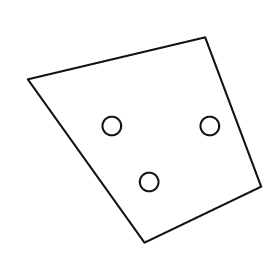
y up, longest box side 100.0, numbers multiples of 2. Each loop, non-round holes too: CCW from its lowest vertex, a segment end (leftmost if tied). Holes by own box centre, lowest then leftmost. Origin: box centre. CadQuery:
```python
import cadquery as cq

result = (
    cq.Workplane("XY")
    .moveTo(0.0, -44.0)
    .lineTo(50.0, -20.0)
    .lineTo(26.0, 44.0)
    .lineTo(-50.0, 26.0)
    .close()
    .moveTo(2.0, -18.0)
    .circle(4.0)
    .moveTo(-14.0, 6.0)
    .circle(4.0)
    .moveTo(28.0, 6.0)
    .circle(4.0)
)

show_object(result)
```